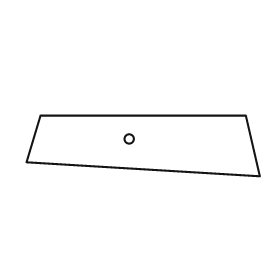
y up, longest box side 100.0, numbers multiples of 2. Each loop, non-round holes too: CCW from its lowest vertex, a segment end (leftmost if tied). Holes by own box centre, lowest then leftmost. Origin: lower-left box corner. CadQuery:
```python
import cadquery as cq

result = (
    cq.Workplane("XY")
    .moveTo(100.0, 0.0)
    .lineTo(94.0, 26.0)
    .lineTo(6.0, 26.0)
    .lineTo(0.0, 6.0)
    .close()
    .moveTo(44.0, 16.0)
    .circle(2.0)
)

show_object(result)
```